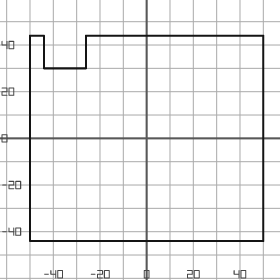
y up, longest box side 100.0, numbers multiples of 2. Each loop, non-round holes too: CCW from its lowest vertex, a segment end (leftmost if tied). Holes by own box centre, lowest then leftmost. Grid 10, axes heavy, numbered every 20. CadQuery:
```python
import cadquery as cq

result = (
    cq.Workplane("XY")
    .moveTo(-50.0, -44.0)
    .lineTo(50.0, -44.0)
    .lineTo(50.0, 44.0)
    .lineTo(-26.0, 44.0)
    .lineTo(-26.0, 30.0)
    .lineTo(-44.0, 30.0)
    .lineTo(-44.0, 44.0)
    .lineTo(-50.0, 44.0)
    .close()
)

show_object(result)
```